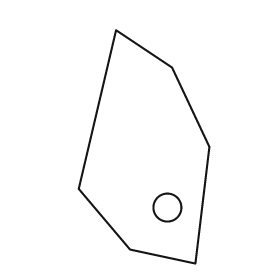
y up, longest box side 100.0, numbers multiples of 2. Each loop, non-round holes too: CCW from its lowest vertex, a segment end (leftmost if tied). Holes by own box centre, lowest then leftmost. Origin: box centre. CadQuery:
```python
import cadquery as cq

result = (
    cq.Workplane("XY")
    .moveTo(22.0, -50.0)
    .lineTo(28.0, 0.0)
    .lineTo(12.0, 34.0)
    .lineTo(-12.0, 50.0)
    .lineTo(-28.0, -18.0)
    .lineTo(-6.0, -44.0)
    .close()
    .moveTo(10.0, -26.0)
    .circle(6.0)
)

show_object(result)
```